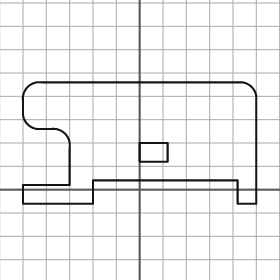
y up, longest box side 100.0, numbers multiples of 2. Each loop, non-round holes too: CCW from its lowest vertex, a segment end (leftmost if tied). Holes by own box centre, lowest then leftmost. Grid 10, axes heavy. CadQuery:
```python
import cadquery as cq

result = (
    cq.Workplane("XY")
    .moveTo(-50.0, -6.0)
    .lineTo(-20.0, -6.0)
    .lineTo(-20.0, 4.0)
    .lineTo(42.0, 4.0)
    .lineTo(42.0, -6.0)
    .lineTo(50.0, -6.0)
    .lineTo(50.0, 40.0)
    .threePointArc((48.0, 44.0), (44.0, 46.0))
    .lineTo(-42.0, 46.0)
    .threePointArc((-48.0, 44.0), (-50.0, 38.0))
    .lineTo(-50.0, 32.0)
    .threePointArc((-48.0, 28.0), (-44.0, 26.0))
    .lineTo(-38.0, 26.0)
    .threePointArc((-32.0, 24.0), (-30.0, 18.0))
    .lineTo(-30.0, 2.0)
    .lineTo(-50.0, 2.0)
    .close()
    .moveTo(0.0, 12.0)
    .lineTo(12.0, 12.0)
    .lineTo(12.0, 20.0)
    .lineTo(0.0, 20.0)
    .close()
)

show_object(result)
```